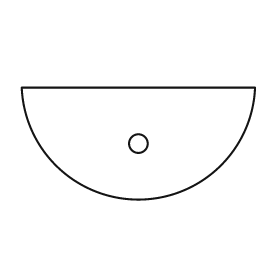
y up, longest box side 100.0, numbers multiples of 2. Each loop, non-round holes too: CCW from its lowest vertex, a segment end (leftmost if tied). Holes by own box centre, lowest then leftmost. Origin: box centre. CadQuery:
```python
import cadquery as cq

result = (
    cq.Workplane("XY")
    .moveTo(-50.0, 24.0)
    .threePointArc((0.0, -24.0), (50.0, 24.0))
    .close()
    .moveTo(0.0, 0.0)
    .circle(4.0)
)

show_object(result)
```